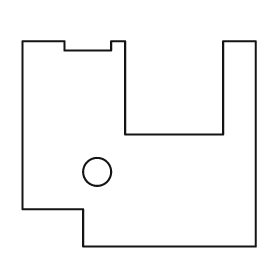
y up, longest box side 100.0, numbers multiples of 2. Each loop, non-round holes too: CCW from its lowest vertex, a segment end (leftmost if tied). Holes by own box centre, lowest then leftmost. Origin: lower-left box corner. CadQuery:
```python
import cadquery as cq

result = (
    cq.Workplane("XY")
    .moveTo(26.0, 0.0)
    .lineTo(100.0, 0.0)
    .lineTo(100.0, 88.0)
    .lineTo(86.0, 88.0)
    .lineTo(86.0, 48.0)
    .lineTo(44.0, 48.0)
    .lineTo(44.0, 88.0)
    .lineTo(38.0, 88.0)
    .lineTo(38.0, 84.0)
    .lineTo(18.0, 84.0)
    .lineTo(18.0, 88.0)
    .lineTo(0.0, 88.0)
    .lineTo(0.0, 16.0)
    .lineTo(26.0, 16.0)
    .close()
    .moveTo(32.0, 32.0)
    .circle(6.0)
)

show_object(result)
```